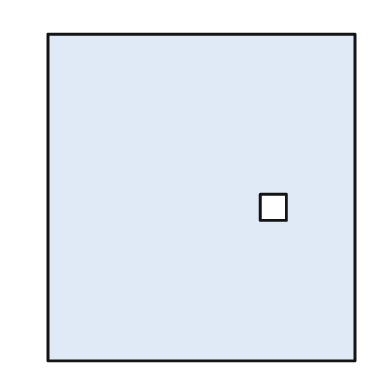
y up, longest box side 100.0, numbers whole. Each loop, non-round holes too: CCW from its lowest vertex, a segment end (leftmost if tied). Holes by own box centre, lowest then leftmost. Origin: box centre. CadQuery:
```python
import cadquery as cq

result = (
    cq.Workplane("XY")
    .moveTo(-47.0, -50.0)
    .lineTo(47.0, -50.0)
    .lineTo(47.0, 50.0)
    .lineTo(-47.0, 50.0)
    .close()
    .moveTo(18.0, -7.0)
    .lineTo(26.0, -7.0)
    .lineTo(26.0, 1.0)
    .lineTo(18.0, 1.0)
    .close()
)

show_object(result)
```